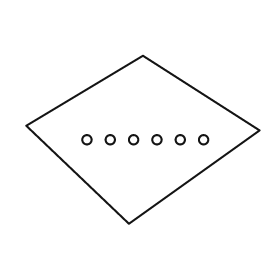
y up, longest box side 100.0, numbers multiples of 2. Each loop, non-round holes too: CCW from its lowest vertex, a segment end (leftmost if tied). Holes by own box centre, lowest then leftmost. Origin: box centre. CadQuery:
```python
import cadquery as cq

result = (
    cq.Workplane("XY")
    .moveTo(-6.0, -36.0)
    .lineTo(50.0, 4.0)
    .lineTo(0.0, 36.0)
    .lineTo(-50.0, 6.0)
    .close()
    .moveTo(-24.0, 0.0)
    .circle(2.0)
    .moveTo(-14.0, 0.0)
    .circle(2.0)
    .moveTo(-4.0, 0.0)
    .circle(2.0)
    .moveTo(6.0, 0.0)
    .circle(2.0)
    .moveTo(16.0, 0.0)
    .circle(2.0)
    .moveTo(26.0, 0.0)
    .circle(2.0)
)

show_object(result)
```